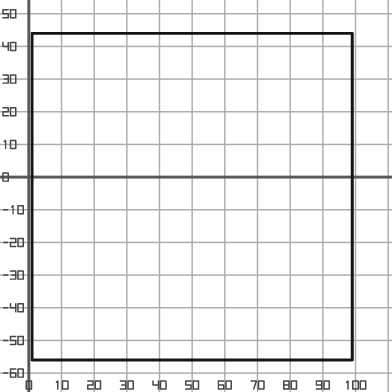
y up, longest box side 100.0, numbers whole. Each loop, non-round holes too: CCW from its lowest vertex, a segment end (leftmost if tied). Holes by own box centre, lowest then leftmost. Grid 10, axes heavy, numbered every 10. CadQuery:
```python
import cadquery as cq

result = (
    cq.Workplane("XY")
    .moveTo(1.0, -56.0)
    .lineTo(99.0, -56.0)
    .lineTo(99.0, 44.0)
    .lineTo(1.0, 44.0)
    .close()
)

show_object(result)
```